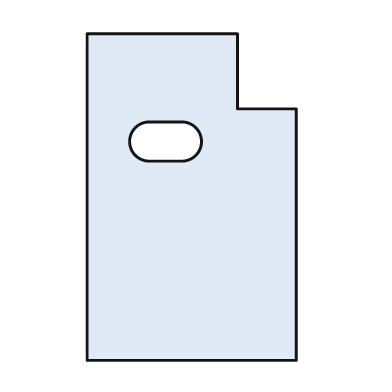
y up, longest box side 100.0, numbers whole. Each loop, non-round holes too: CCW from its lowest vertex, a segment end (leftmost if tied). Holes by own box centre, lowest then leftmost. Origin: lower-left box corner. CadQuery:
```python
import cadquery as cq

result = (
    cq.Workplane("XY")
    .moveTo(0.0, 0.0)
    .lineTo(64.0, 0.0)
    .lineTo(64.0, 77.0)
    .lineTo(46.0, 77.0)
    .lineTo(46.0, 100.0)
    .lineTo(0.0, 100.0)
    .close()
    .moveTo(19.0, 61.0)
    .lineTo(29.0, 61.0)
    .threePointArc((35.0, 67.0), (29.0, 73.0))
    .lineTo(19.0, 73.0)
    .threePointArc((13.0, 67.0), (19.0, 61.0))
    .close()
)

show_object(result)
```